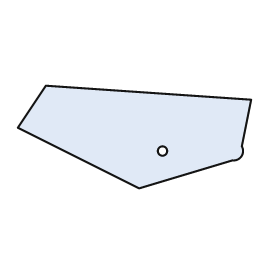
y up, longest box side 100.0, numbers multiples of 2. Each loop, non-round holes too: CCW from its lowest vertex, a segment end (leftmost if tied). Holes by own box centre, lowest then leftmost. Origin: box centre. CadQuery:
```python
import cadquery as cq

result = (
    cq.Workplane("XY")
    .moveTo(2.0, -22.0)
    .lineTo(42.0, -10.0)
    .threePointArc((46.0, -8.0), (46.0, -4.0))
    .lineTo(50.0, 16.0)
    .lineTo(-38.0, 22.0)
    .lineTo(-50.0, 4.0)
    .close()
    .moveTo(12.0, -6.0)
    .circle(2.0)
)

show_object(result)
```